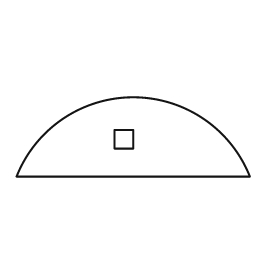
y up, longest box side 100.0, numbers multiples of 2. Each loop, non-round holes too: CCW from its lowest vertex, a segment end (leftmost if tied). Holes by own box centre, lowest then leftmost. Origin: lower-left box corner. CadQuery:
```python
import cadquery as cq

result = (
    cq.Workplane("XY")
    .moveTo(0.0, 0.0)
    .lineTo(100.0, 0.0)
    .threePointArc((50.0, 34.0), (0.0, 0.0))
    .close()
    .moveTo(42.0, 12.0)
    .lineTo(50.0, 12.0)
    .lineTo(50.0, 20.0)
    .lineTo(42.0, 20.0)
    .close()
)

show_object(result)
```